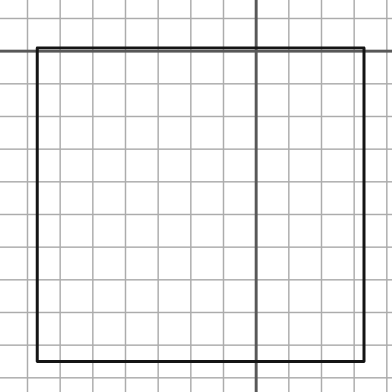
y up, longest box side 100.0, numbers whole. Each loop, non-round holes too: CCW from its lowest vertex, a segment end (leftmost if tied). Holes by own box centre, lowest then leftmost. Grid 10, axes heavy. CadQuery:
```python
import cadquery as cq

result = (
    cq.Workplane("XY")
    .moveTo(-67.0, -95.0)
    .lineTo(33.0, -95.0)
    .lineTo(33.0, 1.0)
    .lineTo(-67.0, 1.0)
    .close()
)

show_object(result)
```